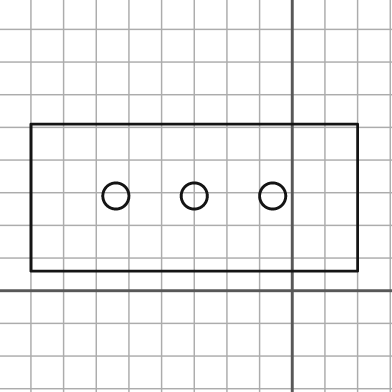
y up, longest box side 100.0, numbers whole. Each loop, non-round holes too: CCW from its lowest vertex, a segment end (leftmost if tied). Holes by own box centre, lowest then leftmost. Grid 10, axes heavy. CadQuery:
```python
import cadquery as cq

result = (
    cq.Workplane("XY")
    .moveTo(-80.0, 6.0)
    .lineTo(20.0, 6.0)
    .lineTo(20.0, 51.0)
    .lineTo(-80.0, 51.0)
    .close()
    .moveTo(-54.0, 29.0)
    .circle(4.0)
    .moveTo(-30.0, 29.0)
    .circle(4.0)
    .moveTo(-6.0, 29.0)
    .circle(4.0)
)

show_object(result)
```